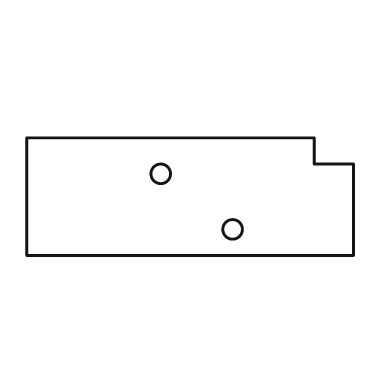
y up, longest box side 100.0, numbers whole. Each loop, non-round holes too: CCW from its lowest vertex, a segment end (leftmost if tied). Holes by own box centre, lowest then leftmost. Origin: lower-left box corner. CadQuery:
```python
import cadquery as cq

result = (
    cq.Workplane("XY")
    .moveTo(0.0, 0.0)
    .lineTo(100.0, 0.0)
    .lineTo(100.0, 28.0)
    .lineTo(88.0, 28.0)
    .lineTo(88.0, 36.0)
    .lineTo(0.0, 36.0)
    .close()
    .moveTo(63.0, 8.0)
    .circle(3.0)
    .moveTo(41.0, 25.0)
    .circle(3.0)
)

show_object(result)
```